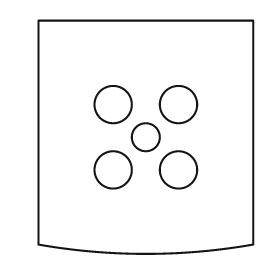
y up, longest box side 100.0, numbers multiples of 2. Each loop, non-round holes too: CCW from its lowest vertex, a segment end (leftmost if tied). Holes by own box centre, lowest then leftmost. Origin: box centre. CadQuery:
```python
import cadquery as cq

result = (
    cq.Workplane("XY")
    .moveTo(-46.0, -46.0)
    .threePointArc((0.0, -50.0), (46.0, -46.0))
    .lineTo(46.0, 50.0)
    .lineTo(-46.0, 50.0)
    .close()
    .moveTo(-14.0, -14.0)
    .circle(8.0)
    .moveTo(14.0, -14.0)
    .circle(8.0)
    .moveTo(0.0, 0.0)
    .circle(6.0)
    .moveTo(-14.0, 14.0)
    .circle(8.0)
    .moveTo(14.0, 14.0)
    .circle(8.0)
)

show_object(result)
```